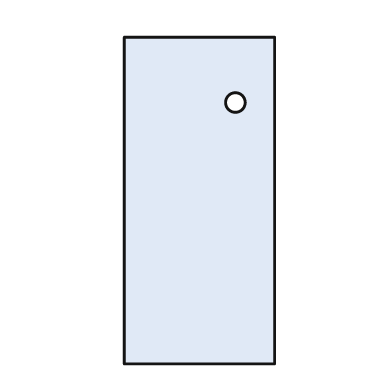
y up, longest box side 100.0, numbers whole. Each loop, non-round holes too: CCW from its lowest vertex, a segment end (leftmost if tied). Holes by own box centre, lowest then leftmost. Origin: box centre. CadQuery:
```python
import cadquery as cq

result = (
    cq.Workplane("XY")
    .moveTo(-23.0, -50.0)
    .lineTo(23.0, -50.0)
    .lineTo(23.0, 50.0)
    .lineTo(-23.0, 50.0)
    .close()
    .moveTo(11.0, 30.0)
    .circle(3.0)
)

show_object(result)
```